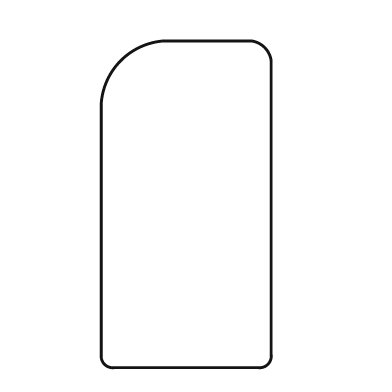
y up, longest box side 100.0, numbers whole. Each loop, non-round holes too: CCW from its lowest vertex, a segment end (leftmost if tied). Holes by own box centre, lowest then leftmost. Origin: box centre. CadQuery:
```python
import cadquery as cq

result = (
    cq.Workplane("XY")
    .moveTo(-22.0, -50.0)
    .lineTo(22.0, -50.0)
    .threePointArc((25.0, -49.0), (26.0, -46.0))
    .lineTo(26.0, 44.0)
    .threePointArc((24.0, 48.0), (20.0, 50.0))
    .lineTo(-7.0, 50.0)
    .threePointArc((-20.0, 44.0), (-26.0, 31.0))
    .lineTo(-26.0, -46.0)
    .threePointArc((-25.0, -49.0), (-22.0, -50.0))
    .close()
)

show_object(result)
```